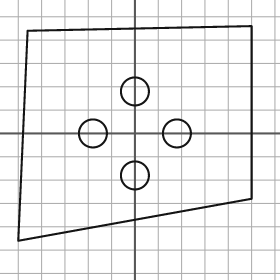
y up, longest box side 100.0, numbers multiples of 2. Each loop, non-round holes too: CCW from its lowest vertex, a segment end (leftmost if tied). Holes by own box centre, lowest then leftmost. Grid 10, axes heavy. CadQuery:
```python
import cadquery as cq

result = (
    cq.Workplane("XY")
    .moveTo(-50.0, -46.0)
    .lineTo(50.0, -28.0)
    .lineTo(50.0, 46.0)
    .lineTo(-46.0, 44.0)
    .close()
    .moveTo(0.0, -18.0)
    .circle(6.0)
    .moveTo(-18.0, 0.0)
    .circle(6.0)
    .moveTo(18.0, 0.0)
    .circle(6.0)
    .moveTo(0.0, 18.0)
    .circle(6.0)
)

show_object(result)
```